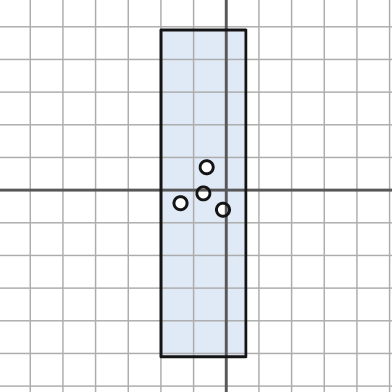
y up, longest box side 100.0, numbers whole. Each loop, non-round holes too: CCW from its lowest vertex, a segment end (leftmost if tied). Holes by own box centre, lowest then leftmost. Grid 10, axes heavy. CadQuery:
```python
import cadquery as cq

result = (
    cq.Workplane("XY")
    .moveTo(-20.0, -51.0)
    .lineTo(6.0, -51.0)
    .lineTo(6.0, 49.0)
    .lineTo(-20.0, 49.0)
    .close()
    .moveTo(-1.0, -6.0)
    .circle(2.0)
    .moveTo(-14.0, -4.0)
    .circle(2.0)
    .moveTo(-7.0, -1.0)
    .circle(2.0)
    .moveTo(-6.0, 7.0)
    .circle(2.0)
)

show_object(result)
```